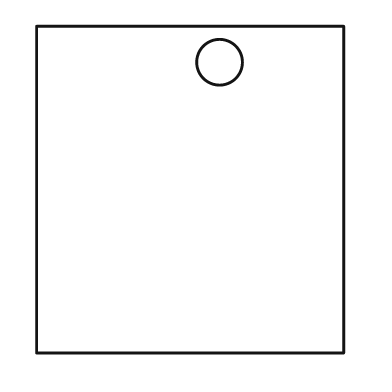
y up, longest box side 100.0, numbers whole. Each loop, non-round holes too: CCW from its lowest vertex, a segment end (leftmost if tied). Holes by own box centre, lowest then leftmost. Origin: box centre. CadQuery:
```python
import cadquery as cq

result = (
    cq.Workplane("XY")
    .moveTo(-47.0, -50.0)
    .lineTo(47.0, -50.0)
    .lineTo(47.0, 50.0)
    .lineTo(-47.0, 50.0)
    .close()
    .moveTo(9.0, 39.0)
    .circle(7.0)
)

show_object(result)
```